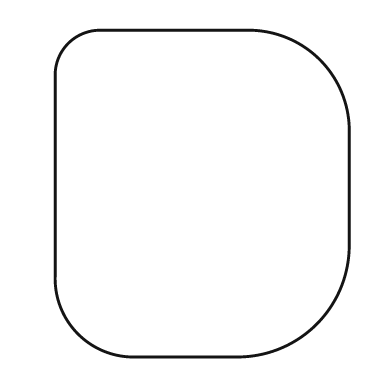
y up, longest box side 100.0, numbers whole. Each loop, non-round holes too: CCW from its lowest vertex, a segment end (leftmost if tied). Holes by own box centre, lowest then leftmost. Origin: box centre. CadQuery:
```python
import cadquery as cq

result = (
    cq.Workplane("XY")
    .moveTo(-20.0, -50.0)
    .lineTo(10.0, -50.0)
    .threePointArc((35.0, -40.0), (45.0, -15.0))
    .lineTo(45.0, 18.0)
    .threePointArc((36.0, 41.0), (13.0, 50.0))
    .lineTo(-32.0, 50.0)
    .threePointArc((-41.0, 46.0), (-45.0, 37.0))
    .lineTo(-45.0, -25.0)
    .threePointArc((-38.0, -43.0), (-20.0, -50.0))
    .close()
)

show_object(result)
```